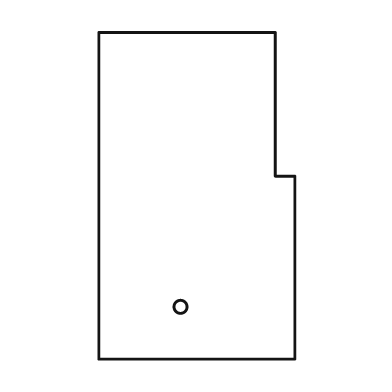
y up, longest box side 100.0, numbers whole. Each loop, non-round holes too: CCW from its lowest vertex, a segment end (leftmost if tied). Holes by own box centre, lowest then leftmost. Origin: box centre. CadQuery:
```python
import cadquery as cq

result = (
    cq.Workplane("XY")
    .moveTo(-30.0, -50.0)
    .lineTo(30.0, -50.0)
    .lineTo(30.0, 6.0)
    .lineTo(24.0, 6.0)
    .lineTo(24.0, 50.0)
    .lineTo(-30.0, 50.0)
    .close()
    .moveTo(-5.0, -34.0)
    .circle(2.0)
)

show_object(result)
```